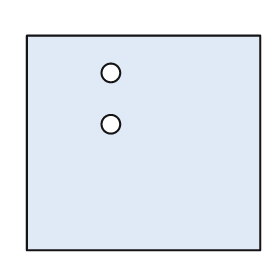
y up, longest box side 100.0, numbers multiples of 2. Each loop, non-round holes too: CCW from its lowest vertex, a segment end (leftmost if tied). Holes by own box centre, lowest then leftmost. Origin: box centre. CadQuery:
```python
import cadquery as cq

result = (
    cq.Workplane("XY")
    .moveTo(-50.0, -46.0)
    .lineTo(50.0, -46.0)
    .lineTo(50.0, 46.0)
    .lineTo(-50.0, 46.0)
    .close()
    .moveTo(-14.0, 8.0)
    .circle(4.0)
    .moveTo(-14.0, 30.0)
    .circle(4.0)
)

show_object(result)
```